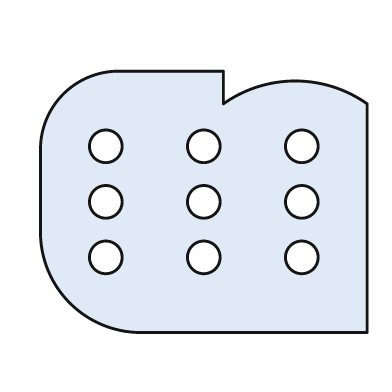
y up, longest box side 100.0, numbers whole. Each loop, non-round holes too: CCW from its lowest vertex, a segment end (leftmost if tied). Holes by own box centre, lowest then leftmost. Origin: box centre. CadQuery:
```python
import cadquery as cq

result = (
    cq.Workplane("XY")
    .moveTo(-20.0, -40.0)
    .lineTo(50.0, -40.0)
    .lineTo(50.0, 30.0)
    .threePointArc((28.0, 37.0), (6.0, 30.0))
    .lineTo(6.0, 40.0)
    .lineTo(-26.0, 40.0)
    .threePointArc((-43.0, 33.0), (-50.0, 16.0))
    .lineTo(-50.0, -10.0)
    .threePointArc((-41.0, -31.0), (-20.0, -40.0))
    .close()
    .moveTo(-30.0, -17.0)
    .circle(5.0)
    .moveTo(0.0, -17.0)
    .circle(5.0)
    .moveTo(30.0, -17.0)
    .circle(5.0)
    .moveTo(-30.0, 0.0)
    .circle(5.0)
    .moveTo(0.0, 0.0)
    .circle(5.0)
    .moveTo(30.0, 0.0)
    .circle(5.0)
    .moveTo(-30.0, 17.0)
    .circle(5.0)
    .moveTo(0.0, 17.0)
    .circle(5.0)
    .moveTo(30.0, 17.0)
    .circle(5.0)
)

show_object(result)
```